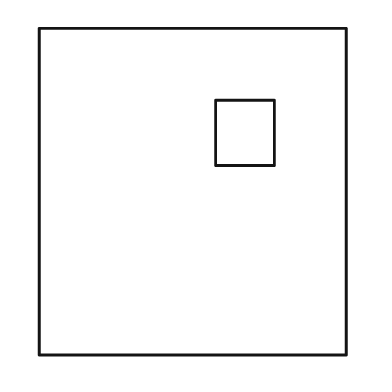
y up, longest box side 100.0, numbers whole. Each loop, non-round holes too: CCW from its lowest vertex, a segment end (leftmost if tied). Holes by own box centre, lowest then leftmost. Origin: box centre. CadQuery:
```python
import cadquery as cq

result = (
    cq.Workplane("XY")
    .moveTo(-47.0, -50.0)
    .lineTo(47.0, -50.0)
    .lineTo(47.0, 50.0)
    .lineTo(-47.0, 50.0)
    .close()
    .moveTo(7.0, 8.0)
    .lineTo(25.0, 8.0)
    .lineTo(25.0, 28.0)
    .lineTo(7.0, 28.0)
    .close()
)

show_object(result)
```